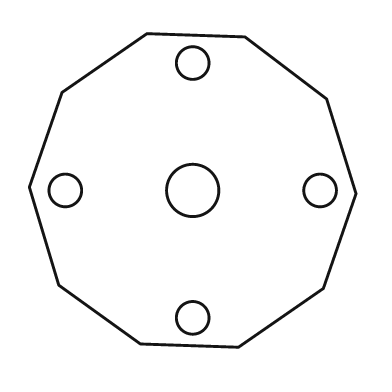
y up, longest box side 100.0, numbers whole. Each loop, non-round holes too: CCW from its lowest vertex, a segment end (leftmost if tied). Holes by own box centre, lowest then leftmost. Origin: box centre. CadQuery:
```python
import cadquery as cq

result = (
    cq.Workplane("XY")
    .moveTo(14.0, -48.0)
    .lineTo(40.0, -30.0)
    .lineTo(50.0, -1.0)
    .lineTo(41.0, 28.0)
    .lineTo(16.0, 47.0)
    .lineTo(-14.0, 48.0)
    .lineTo(-40.0, 30.0)
    .lineTo(-50.0, 1.0)
    .lineTo(-41.0, -29.0)
    .lineTo(-16.0, -47.0)
    .close()
    .moveTo(0.0, -39.0)
    .circle(5.0)
    .moveTo(-39.0, 0.0)
    .circle(5.0)
    .moveTo(0.0, 0.0)
    .circle(8.0)
    .moveTo(39.0, 0.0)
    .circle(5.0)
    .moveTo(0.0, 39.0)
    .circle(5.0)
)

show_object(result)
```